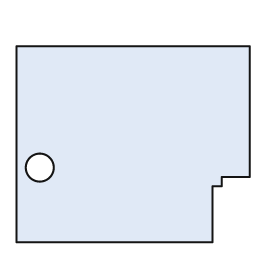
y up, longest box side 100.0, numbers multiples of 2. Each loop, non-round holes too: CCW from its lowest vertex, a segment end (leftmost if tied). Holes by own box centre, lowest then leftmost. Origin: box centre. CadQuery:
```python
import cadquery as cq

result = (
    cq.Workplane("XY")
    .moveTo(-50.0, -42.0)
    .lineTo(34.0, -42.0)
    .lineTo(34.0, -18.0)
    .lineTo(38.0, -18.0)
    .lineTo(38.0, -14.0)
    .lineTo(50.0, -14.0)
    .lineTo(50.0, 42.0)
    .lineTo(-50.0, 42.0)
    .close()
    .moveTo(-40.0, -10.0)
    .circle(6.0)
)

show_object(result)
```